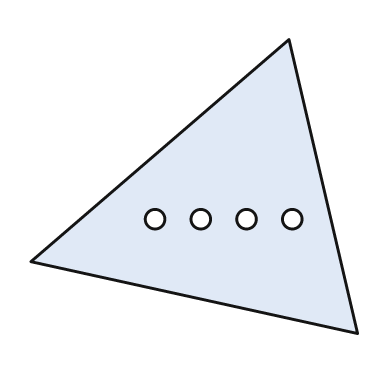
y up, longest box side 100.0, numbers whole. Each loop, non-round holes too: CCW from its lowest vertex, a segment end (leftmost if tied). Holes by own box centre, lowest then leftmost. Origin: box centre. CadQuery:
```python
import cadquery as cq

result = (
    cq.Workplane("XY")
    .moveTo(50.0, -45.0)
    .lineTo(29.0, 45.0)
    .lineTo(-50.0, -23.0)
    .close()
    .moveTo(-12.0, -10.0)
    .circle(3.0)
    .moveTo(2.0, -10.0)
    .circle(3.0)
    .moveTo(16.0, -10.0)
    .circle(3.0)
    .moveTo(30.0, -10.0)
    .circle(3.0)
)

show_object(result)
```